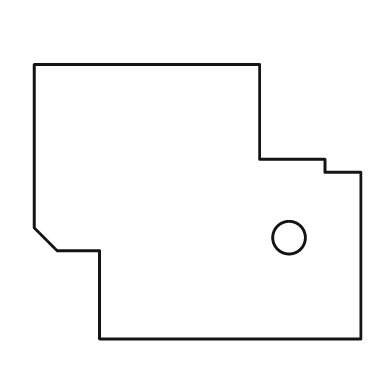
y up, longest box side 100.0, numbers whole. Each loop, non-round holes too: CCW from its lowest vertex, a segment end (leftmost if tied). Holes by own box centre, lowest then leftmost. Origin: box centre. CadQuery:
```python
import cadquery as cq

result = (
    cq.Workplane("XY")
    .moveTo(-30.0, -42.0)
    .lineTo(50.0, -42.0)
    .lineTo(50.0, 9.0)
    .lineTo(39.0, 9.0)
    .lineTo(39.0, 13.0)
    .lineTo(19.0, 13.0)
    .lineTo(19.0, 42.0)
    .lineTo(-50.0, 42.0)
    .lineTo(-50.0, -8.0)
    .lineTo(-43.0, -15.0)
    .lineTo(-30.0, -15.0)
    .close()
    .moveTo(28.0, -11.0)
    .circle(5.0)
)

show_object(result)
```